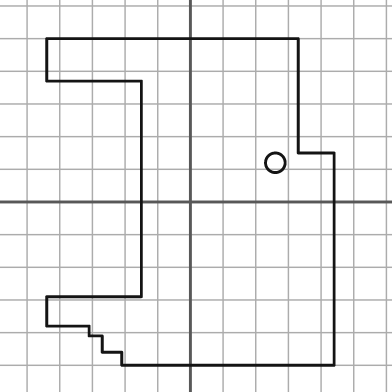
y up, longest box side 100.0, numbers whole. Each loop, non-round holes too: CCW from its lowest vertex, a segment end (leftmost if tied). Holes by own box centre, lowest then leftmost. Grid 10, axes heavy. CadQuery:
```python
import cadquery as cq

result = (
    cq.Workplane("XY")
    .moveTo(-21.0, -50.0)
    .lineTo(44.0, -50.0)
    .lineTo(44.0, 15.0)
    .lineTo(33.0, 15.0)
    .lineTo(33.0, 50.0)
    .lineTo(-44.0, 50.0)
    .lineTo(-44.0, 37.0)
    .lineTo(-15.0, 37.0)
    .lineTo(-15.0, -29.0)
    .lineTo(-44.0, -29.0)
    .lineTo(-44.0, -38.0)
    .lineTo(-31.0, -38.0)
    .lineTo(-31.0, -41.0)
    .lineTo(-27.0, -41.0)
    .lineTo(-27.0, -46.0)
    .lineTo(-21.0, -46.0)
    .close()
    .moveTo(26.0, 12.0)
    .circle(3.0)
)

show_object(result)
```